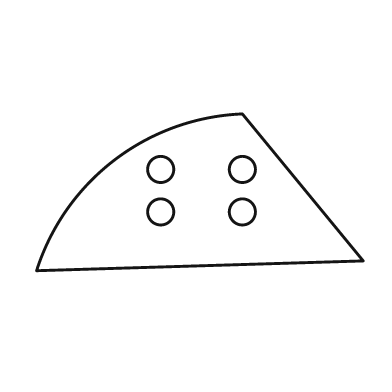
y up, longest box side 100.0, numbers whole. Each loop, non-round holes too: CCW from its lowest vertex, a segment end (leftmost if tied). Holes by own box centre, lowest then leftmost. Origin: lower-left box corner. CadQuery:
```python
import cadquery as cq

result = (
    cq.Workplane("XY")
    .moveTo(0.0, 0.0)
    .lineTo(100.0, 3.0)
    .lineTo(63.0, 48.0)
    .threePointArc((24.0, 34.0), (0.0, 0.0))
    .close()
    .moveTo(38.0, 18.0)
    .circle(4.0)
    .moveTo(63.0, 18.0)
    .circle(4.0)
    .moveTo(38.0, 31.0)
    .circle(4.0)
    .moveTo(63.0, 31.0)
    .circle(4.0)
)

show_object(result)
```